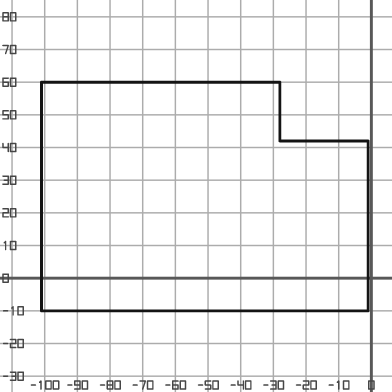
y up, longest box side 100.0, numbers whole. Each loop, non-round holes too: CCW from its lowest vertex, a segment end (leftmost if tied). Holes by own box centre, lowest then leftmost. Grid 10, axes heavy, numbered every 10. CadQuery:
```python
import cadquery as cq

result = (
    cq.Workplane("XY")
    .moveTo(-101.0, -10.0)
    .lineTo(-1.0, -10.0)
    .lineTo(-1.0, 42.0)
    .lineTo(-28.0, 42.0)
    .lineTo(-28.0, 60.0)
    .lineTo(-101.0, 60.0)
    .close()
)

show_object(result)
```